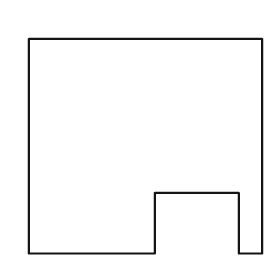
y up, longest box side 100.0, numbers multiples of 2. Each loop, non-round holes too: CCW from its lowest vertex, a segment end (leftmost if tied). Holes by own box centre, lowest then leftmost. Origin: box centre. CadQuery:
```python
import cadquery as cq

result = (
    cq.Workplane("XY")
    .moveTo(-50.0, -46.0)
    .lineTo(4.0, -46.0)
    .lineTo(4.0, -20.0)
    .lineTo(40.0, -20.0)
    .lineTo(40.0, -46.0)
    .lineTo(50.0, -46.0)
    .lineTo(50.0, 46.0)
    .lineTo(-50.0, 46.0)
    .close()
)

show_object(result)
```